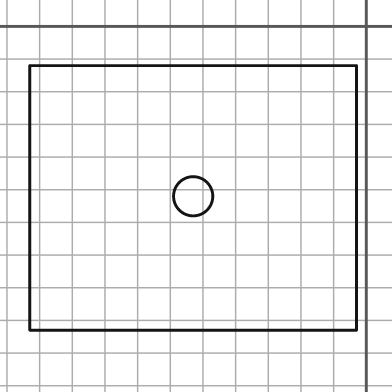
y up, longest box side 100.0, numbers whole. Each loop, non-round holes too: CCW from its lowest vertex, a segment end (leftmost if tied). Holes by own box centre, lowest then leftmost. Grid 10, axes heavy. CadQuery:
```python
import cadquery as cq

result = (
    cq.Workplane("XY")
    .moveTo(-103.0, -93.0)
    .lineTo(-3.0, -93.0)
    .lineTo(-3.0, -12.0)
    .lineTo(-103.0, -12.0)
    .close()
    .moveTo(-53.0, -52.0)
    .circle(6.0)
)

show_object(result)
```